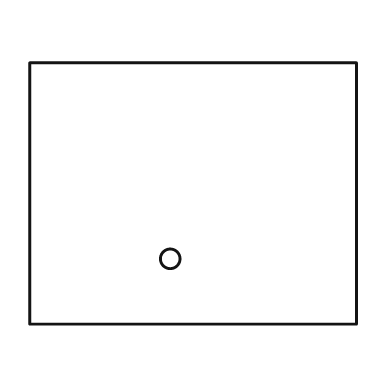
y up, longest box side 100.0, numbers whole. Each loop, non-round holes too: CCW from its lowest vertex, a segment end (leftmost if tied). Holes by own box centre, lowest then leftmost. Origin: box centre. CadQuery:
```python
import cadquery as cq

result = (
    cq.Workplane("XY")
    .moveTo(-50.0, -40.0)
    .lineTo(50.0, -40.0)
    .lineTo(50.0, 40.0)
    .lineTo(-50.0, 40.0)
    .close()
    .moveTo(-7.0, -20.0)
    .circle(3.0)
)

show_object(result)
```